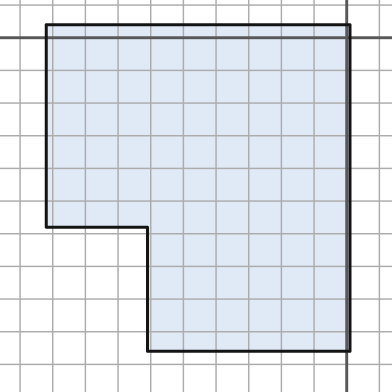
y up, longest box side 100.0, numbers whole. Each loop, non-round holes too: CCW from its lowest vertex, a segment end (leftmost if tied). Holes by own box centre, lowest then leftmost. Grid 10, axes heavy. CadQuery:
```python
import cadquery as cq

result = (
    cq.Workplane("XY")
    .moveTo(-61.0, -96.0)
    .lineTo(1.0, -96.0)
    .lineTo(1.0, 4.0)
    .lineTo(-92.0, 4.0)
    .lineTo(-92.0, -58.0)
    .lineTo(-61.0, -58.0)
    .close()
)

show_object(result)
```